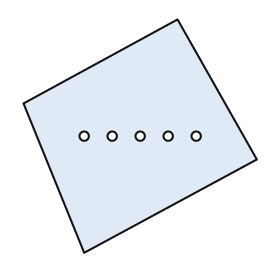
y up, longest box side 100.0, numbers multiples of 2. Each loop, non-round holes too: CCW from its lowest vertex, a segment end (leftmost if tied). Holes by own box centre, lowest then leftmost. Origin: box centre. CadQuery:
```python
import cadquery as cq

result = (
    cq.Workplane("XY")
    .moveTo(-24.0, -50.0)
    .lineTo(50.0, -10.0)
    .lineTo(16.0, 50.0)
    .lineTo(-50.0, 14.0)
    .close()
    .moveTo(-24.0, 0.0)
    .circle(2.0)
    .moveTo(-12.0, 0.0)
    .circle(2.0)
    .moveTo(0.0, 0.0)
    .circle(2.0)
    .moveTo(12.0, 0.0)
    .circle(2.0)
    .moveTo(24.0, 0.0)
    .circle(2.0)
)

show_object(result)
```